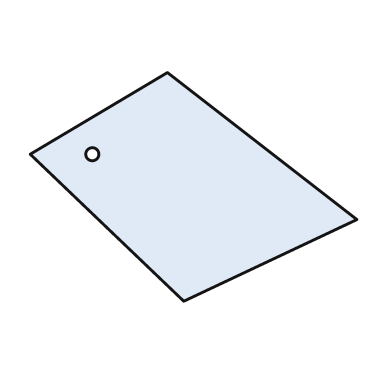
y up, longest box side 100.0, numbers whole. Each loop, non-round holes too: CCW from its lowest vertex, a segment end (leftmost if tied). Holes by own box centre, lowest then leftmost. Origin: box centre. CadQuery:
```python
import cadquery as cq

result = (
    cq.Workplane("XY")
    .moveTo(-3.0, -35.0)
    .lineTo(50.0, -10.0)
    .lineTo(-8.0, 35.0)
    .lineTo(-50.0, 10.0)
    .close()
    .moveTo(-31.0, 10.0)
    .circle(2.0)
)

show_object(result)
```